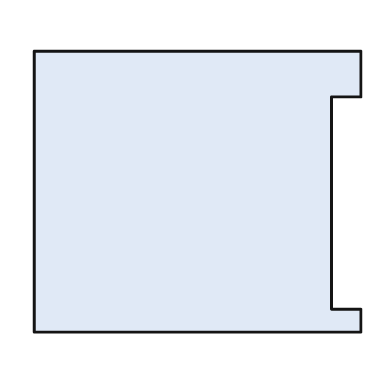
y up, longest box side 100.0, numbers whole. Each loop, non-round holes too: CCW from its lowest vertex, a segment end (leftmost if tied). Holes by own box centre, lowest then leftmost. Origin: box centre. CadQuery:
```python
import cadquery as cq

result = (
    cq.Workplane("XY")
    .moveTo(-50.0, -43.0)
    .lineTo(50.0, -43.0)
    .lineTo(50.0, -36.0)
    .lineTo(41.0, -36.0)
    .lineTo(41.0, 29.0)
    .lineTo(50.0, 29.0)
    .lineTo(50.0, 43.0)
    .lineTo(-50.0, 43.0)
    .close()
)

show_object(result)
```